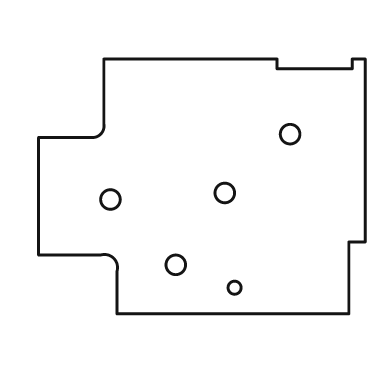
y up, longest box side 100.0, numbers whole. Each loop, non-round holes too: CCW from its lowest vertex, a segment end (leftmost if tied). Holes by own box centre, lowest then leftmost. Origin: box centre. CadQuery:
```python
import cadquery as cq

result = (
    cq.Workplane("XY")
    .moveTo(-26.0, -39.0)
    .lineTo(45.0, -39.0)
    .lineTo(45.0, -17.0)
    .lineTo(50.0, -17.0)
    .lineTo(50.0, 39.0)
    .lineTo(46.0, 39.0)
    .lineTo(46.0, 36.0)
    .lineTo(23.0, 36.0)
    .lineTo(23.0, 39.0)
    .lineTo(-30.0, 39.0)
    .lineTo(-30.0, 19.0)
    .threePointArc((-31.0, 16.0), (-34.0, 15.0))
    .lineTo(-50.0, 15.0)
    .lineTo(-50.0, -21.0)
    .lineTo(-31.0, -21.0)
    .threePointArc((-27.0, -22.0), (-26.0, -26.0))
    .close()
    .moveTo(10.0, -31.0)
    .circle(2.0)
    .moveTo(-8.0, -24.0)
    .circle(3.0)
    .moveTo(-28.0, -4.0)
    .circle(3.0)
    .moveTo(7.0, -2.0)
    .circle(3.0)
    .moveTo(27.0, 16.0)
    .circle(3.0)
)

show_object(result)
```